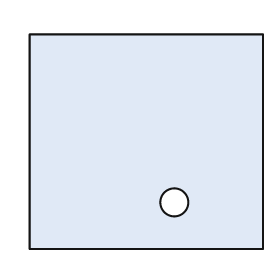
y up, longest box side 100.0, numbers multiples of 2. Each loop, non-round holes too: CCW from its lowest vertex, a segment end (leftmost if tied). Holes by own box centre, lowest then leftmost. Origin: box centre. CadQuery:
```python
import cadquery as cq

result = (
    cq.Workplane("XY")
    .moveTo(-50.0, -46.0)
    .lineTo(50.0, -46.0)
    .lineTo(50.0, 46.0)
    .lineTo(-50.0, 46.0)
    .close()
    .moveTo(12.0, -26.0)
    .circle(6.0)
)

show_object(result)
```